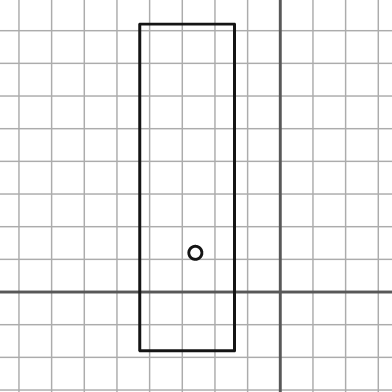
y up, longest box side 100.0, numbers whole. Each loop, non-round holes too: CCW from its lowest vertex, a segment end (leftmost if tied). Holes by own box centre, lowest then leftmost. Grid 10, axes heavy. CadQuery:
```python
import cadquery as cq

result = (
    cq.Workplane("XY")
    .moveTo(-43.0, -18.0)
    .lineTo(-14.0, -18.0)
    .lineTo(-14.0, 82.0)
    .lineTo(-43.0, 82.0)
    .close()
    .moveTo(-26.0, 12.0)
    .circle(2.0)
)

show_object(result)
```